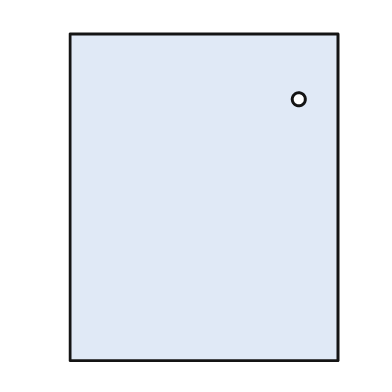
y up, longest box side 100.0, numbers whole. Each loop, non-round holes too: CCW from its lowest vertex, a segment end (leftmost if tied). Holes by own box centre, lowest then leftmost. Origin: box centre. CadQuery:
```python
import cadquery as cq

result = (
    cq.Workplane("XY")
    .moveTo(-41.0, -50.0)
    .lineTo(41.0, -50.0)
    .lineTo(41.0, 50.0)
    .lineTo(-41.0, 50.0)
    .close()
    .moveTo(29.0, 30.0)
    .circle(2.0)
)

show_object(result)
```